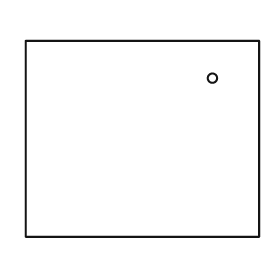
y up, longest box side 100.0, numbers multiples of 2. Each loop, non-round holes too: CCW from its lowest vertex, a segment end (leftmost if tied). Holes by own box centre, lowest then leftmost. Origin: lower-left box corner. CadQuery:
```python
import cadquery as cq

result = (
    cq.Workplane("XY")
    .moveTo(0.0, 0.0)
    .lineTo(100.0, 0.0)
    .lineTo(100.0, 84.0)
    .lineTo(0.0, 84.0)
    .close()
    .moveTo(80.0, 68.0)
    .circle(2.0)
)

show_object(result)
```